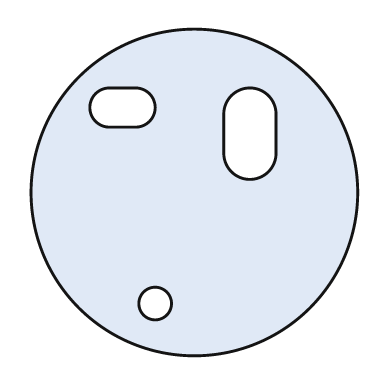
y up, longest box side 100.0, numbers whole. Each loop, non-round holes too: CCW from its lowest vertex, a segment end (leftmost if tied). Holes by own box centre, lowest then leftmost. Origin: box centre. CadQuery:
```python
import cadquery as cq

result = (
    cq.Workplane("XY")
    .moveTo(0.0, 0.0)
    .circle(50.0)
    .moveTo(-12.0, -34.0)
    .circle(5.0)
    .moveTo(9.0, 12.0)
    .threePointArc((17.0, 4.0), (25.0, 12.0))
    .lineTo(25.0, 24.0)
    .threePointArc((17.0, 32.0), (9.0, 24.0))
    .close()
    .moveTo(-26.0, 20.0)
    .lineTo(-18.0, 20.0)
    .threePointArc((-12.0, 26.0), (-18.0, 32.0))
    .lineTo(-26.0, 32.0)
    .threePointArc((-32.0, 26.0), (-26.0, 20.0))
    .close()
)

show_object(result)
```